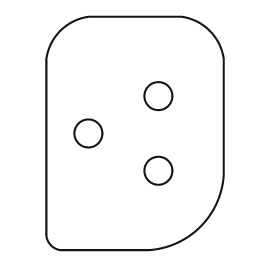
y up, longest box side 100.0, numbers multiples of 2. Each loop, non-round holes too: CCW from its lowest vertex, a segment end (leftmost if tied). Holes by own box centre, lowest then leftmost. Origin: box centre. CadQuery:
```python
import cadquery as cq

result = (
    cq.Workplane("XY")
    .moveTo(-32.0, -50.0)
    .lineTo(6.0, -50.0)
    .threePointArc((28.0, -40.0), (38.0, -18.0))
    .lineTo(38.0, 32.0)
    .threePointArc((32.0, 44.0), (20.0, 50.0))
    .lineTo(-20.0, 50.0)
    .threePointArc((-32.0, 44.0), (-38.0, 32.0))
    .lineTo(-38.0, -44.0)
    .threePointArc((-36.0, -48.0), (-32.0, -50.0))
    .close()
    .moveTo(10.0, -16.0)
    .circle(6.0)
    .moveTo(-20.0, 0.0)
    .circle(6.0)
    .moveTo(10.0, 16.0)
    .circle(6.0)
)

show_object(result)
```